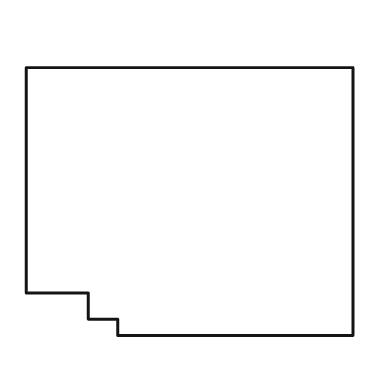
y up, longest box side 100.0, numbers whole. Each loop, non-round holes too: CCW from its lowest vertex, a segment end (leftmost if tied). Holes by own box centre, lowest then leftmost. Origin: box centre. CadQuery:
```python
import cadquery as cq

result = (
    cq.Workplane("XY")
    .moveTo(-22.0, -41.0)
    .lineTo(50.0, -41.0)
    .lineTo(50.0, 41.0)
    .lineTo(-50.0, 41.0)
    .lineTo(-50.0, -28.0)
    .lineTo(-31.0, -28.0)
    .lineTo(-31.0, -36.0)
    .lineTo(-22.0, -36.0)
    .close()
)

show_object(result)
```